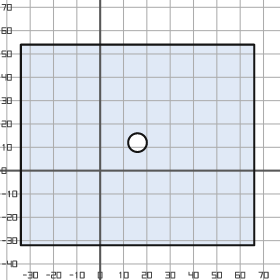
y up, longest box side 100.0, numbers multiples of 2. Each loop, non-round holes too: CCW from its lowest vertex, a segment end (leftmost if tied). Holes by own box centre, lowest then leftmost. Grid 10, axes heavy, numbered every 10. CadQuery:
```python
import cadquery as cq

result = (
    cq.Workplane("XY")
    .moveTo(-34.0, -32.0)
    .lineTo(66.0, -32.0)
    .lineTo(66.0, 54.0)
    .lineTo(-34.0, 54.0)
    .close()
    .moveTo(16.0, 12.0)
    .circle(4.0)
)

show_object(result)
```